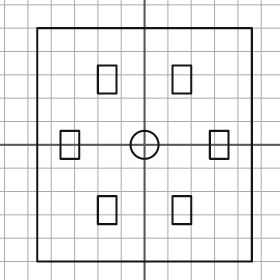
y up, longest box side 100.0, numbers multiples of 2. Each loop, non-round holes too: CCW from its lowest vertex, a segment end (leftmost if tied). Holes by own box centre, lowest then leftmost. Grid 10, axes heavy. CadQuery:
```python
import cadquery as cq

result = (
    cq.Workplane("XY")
    .moveTo(-46.0, -50.0)
    .lineTo(46.0, -50.0)
    .lineTo(46.0, 50.0)
    .lineTo(-46.0, 50.0)
    .close()
    .moveTo(-20.0, -34.0)
    .lineTo(-12.0, -34.0)
    .lineTo(-12.0, -22.0)
    .lineTo(-20.0, -22.0)
    .close()
    .moveTo(12.0, -34.0)
    .lineTo(20.0, -34.0)
    .lineTo(20.0, -22.0)
    .lineTo(12.0, -22.0)
    .close()
    .moveTo(-36.0, -6.0)
    .lineTo(-28.0, -6.0)
    .lineTo(-28.0, 6.0)
    .lineTo(-36.0, 6.0)
    .close()
    .moveTo(0.0, 0.0)
    .circle(6.0)
    .moveTo(28.0, -6.0)
    .lineTo(36.0, -6.0)
    .lineTo(36.0, 6.0)
    .lineTo(28.0, 6.0)
    .close()
    .moveTo(-20.0, 22.0)
    .lineTo(-12.0, 22.0)
    .lineTo(-12.0, 34.0)
    .lineTo(-20.0, 34.0)
    .close()
    .moveTo(12.0, 22.0)
    .lineTo(20.0, 22.0)
    .lineTo(20.0, 34.0)
    .lineTo(12.0, 34.0)
    .close()
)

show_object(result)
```